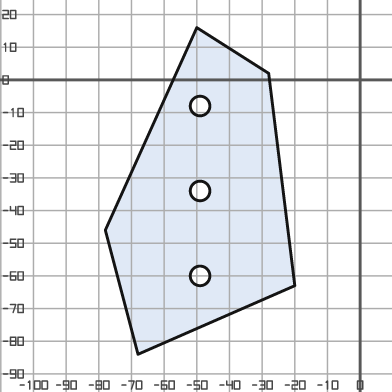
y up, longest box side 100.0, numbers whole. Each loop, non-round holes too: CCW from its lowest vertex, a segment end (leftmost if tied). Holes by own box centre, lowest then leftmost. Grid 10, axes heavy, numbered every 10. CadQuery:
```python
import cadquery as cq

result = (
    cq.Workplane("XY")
    .moveTo(-68.0, -84.0)
    .lineTo(-20.0, -63.0)
    .lineTo(-28.0, 2.0)
    .lineTo(-50.0, 16.0)
    .lineTo(-78.0, -46.0)
    .close()
    .moveTo(-49.0, -60.0)
    .circle(3.0)
    .moveTo(-49.0, -34.0)
    .circle(3.0)
    .moveTo(-49.0, -8.0)
    .circle(3.0)
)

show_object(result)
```